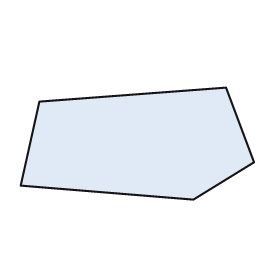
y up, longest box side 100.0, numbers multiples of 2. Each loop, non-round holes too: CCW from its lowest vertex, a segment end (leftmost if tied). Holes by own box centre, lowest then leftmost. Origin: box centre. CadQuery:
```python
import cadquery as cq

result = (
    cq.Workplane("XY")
    .moveTo(24.0, -24.0)
    .lineTo(50.0, -8.0)
    .lineTo(38.0, 24.0)
    .lineTo(-42.0, 18.0)
    .lineTo(-50.0, -18.0)
    .close()
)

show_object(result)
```